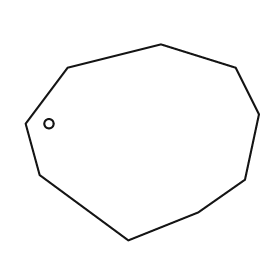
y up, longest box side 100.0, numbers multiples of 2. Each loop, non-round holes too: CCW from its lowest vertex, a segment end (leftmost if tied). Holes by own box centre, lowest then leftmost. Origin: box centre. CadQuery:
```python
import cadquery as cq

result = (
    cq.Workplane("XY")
    .moveTo(-6.0, -42.0)
    .lineTo(24.0, -30.0)
    .lineTo(44.0, -16.0)
    .lineTo(50.0, 12.0)
    .lineTo(40.0, 32.0)
    .lineTo(8.0, 42.0)
    .lineTo(-32.0, 32.0)
    .lineTo(-50.0, 8.0)
    .lineTo(-44.0, -14.0)
    .close()
    .moveTo(-40.0, 8.0)
    .circle(2.0)
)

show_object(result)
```